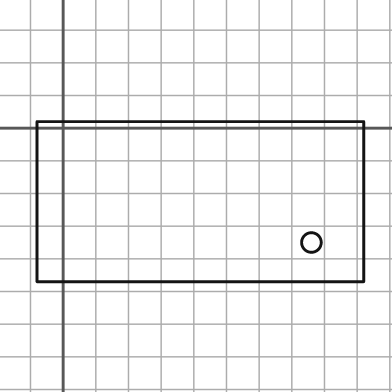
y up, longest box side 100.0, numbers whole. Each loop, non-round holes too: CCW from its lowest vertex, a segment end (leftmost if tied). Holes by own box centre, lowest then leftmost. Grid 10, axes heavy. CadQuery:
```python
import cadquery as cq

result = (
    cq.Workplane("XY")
    .moveTo(-8.0, -47.0)
    .lineTo(92.0, -47.0)
    .lineTo(92.0, 2.0)
    .lineTo(-8.0, 2.0)
    .close()
    .moveTo(76.0, -35.0)
    .circle(3.0)
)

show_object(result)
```